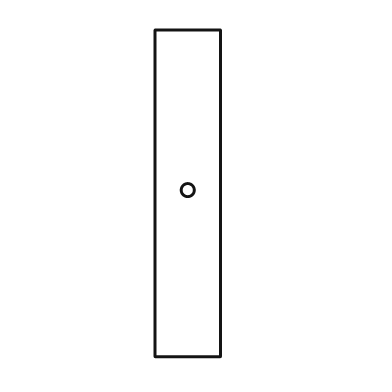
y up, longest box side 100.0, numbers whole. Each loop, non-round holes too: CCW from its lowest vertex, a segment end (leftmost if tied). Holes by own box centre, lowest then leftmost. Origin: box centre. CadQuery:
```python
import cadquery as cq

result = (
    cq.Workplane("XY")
    .moveTo(-10.0, -50.0)
    .lineTo(10.0, -50.0)
    .lineTo(10.0, 50.0)
    .lineTo(-10.0, 50.0)
    .close()
    .moveTo(0.0, 1.0)
    .circle(2.0)
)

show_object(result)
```